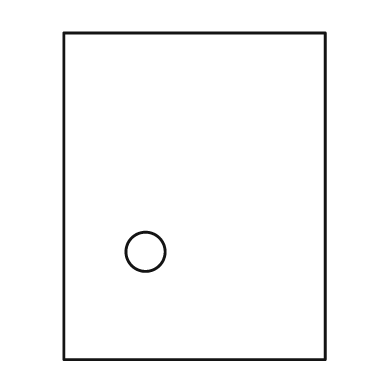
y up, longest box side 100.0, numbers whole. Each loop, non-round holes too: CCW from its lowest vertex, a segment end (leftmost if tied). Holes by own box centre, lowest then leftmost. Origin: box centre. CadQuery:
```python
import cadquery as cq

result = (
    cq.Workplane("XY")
    .moveTo(-40.0, -50.0)
    .lineTo(40.0, -50.0)
    .lineTo(40.0, 50.0)
    .lineTo(-40.0, 50.0)
    .close()
    .moveTo(-15.0, -17.0)
    .circle(6.0)
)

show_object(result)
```